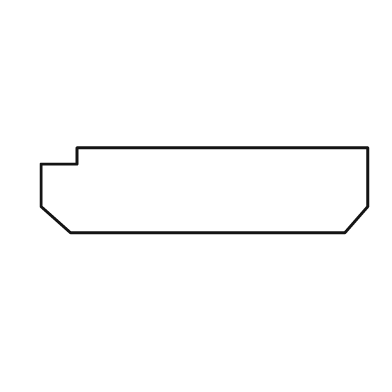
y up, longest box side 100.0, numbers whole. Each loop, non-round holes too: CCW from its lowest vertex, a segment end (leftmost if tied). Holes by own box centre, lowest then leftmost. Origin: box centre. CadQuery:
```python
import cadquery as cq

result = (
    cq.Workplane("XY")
    .moveTo(-41.0, -13.0)
    .lineTo(43.0, -13.0)
    .lineTo(50.0, -5.0)
    .lineTo(50.0, 13.0)
    .lineTo(-39.0, 13.0)
    .lineTo(-39.0, 8.0)
    .lineTo(-50.0, 8.0)
    .lineTo(-50.0, -5.0)
    .close()
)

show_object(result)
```